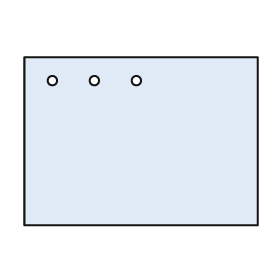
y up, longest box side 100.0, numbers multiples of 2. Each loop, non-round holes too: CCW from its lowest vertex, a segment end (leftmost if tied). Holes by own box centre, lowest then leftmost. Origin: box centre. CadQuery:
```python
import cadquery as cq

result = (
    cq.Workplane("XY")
    .moveTo(-50.0, -36.0)
    .lineTo(50.0, -36.0)
    .lineTo(50.0, 36.0)
    .lineTo(-50.0, 36.0)
    .close()
    .moveTo(-38.0, 26.0)
    .circle(2.0)
    .moveTo(-20.0, 26.0)
    .circle(2.0)
    .moveTo(-2.0, 26.0)
    .circle(2.0)
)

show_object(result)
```